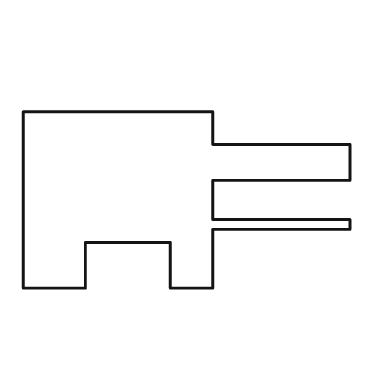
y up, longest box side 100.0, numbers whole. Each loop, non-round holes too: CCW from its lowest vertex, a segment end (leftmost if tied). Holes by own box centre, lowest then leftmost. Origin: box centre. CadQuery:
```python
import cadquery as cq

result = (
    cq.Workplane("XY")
    .moveTo(-50.0, -27.0)
    .lineTo(-31.0, -27.0)
    .lineTo(-31.0, -13.0)
    .lineTo(-5.0, -13.0)
    .lineTo(-5.0, -27.0)
    .lineTo(8.0, -27.0)
    .lineTo(8.0, -9.0)
    .lineTo(50.0, -9.0)
    .lineTo(50.0, -6.0)
    .lineTo(8.0, -6.0)
    .lineTo(8.0, 6.0)
    .lineTo(50.0, 6.0)
    .lineTo(50.0, 17.0)
    .lineTo(8.0, 17.0)
    .lineTo(8.0, 27.0)
    .lineTo(-50.0, 27.0)
    .close()
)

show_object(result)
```